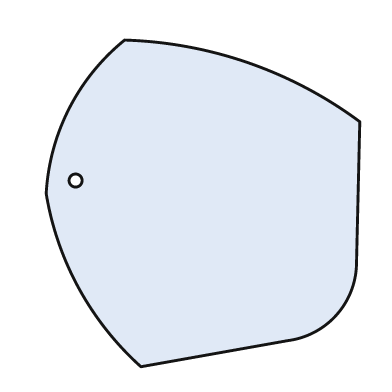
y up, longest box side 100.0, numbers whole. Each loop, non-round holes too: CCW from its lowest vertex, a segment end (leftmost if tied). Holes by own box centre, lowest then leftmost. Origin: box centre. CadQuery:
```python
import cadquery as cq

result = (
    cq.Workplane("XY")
    .moveTo(-19.0, -50.0)
    .lineTo(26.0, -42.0)
    .threePointArc((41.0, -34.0), (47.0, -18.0))
    .lineTo(48.0, 25.0)
    .threePointArc((14.0, 43.0), (-24.0, 50.0))
    .threePointArc((-41.0, 29.0), (-48.0, 3.0))
    .threePointArc((-38.0, -26.0), (-19.0, -50.0))
    .close()
    .moveTo(-39.0, 7.0)
    .circle(2.0)
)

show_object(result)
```